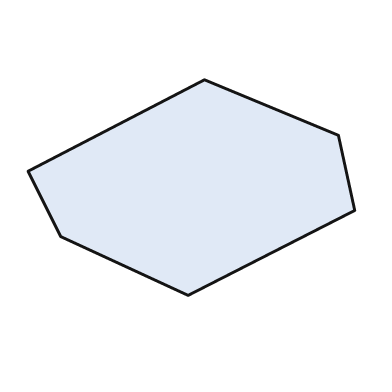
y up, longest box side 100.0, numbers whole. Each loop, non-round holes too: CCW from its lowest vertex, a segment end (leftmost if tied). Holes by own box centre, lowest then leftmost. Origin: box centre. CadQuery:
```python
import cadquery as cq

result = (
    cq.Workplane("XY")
    .moveTo(-1.0, -33.0)
    .lineTo(50.0, -7.0)
    .lineTo(45.0, 16.0)
    .lineTo(4.0, 33.0)
    .lineTo(-50.0, 5.0)
    .lineTo(-40.0, -15.0)
    .close()
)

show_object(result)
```